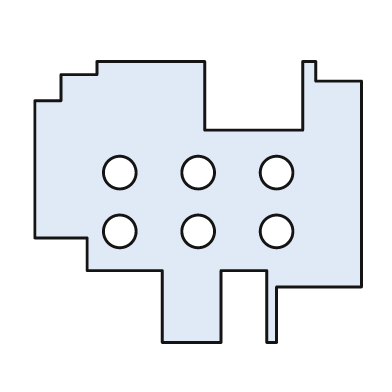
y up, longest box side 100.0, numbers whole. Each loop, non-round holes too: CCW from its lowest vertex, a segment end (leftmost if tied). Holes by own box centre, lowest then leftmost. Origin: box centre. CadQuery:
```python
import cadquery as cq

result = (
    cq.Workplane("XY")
    .moveTo(-11.0, -43.0)
    .lineTo(7.0, -43.0)
    .lineTo(7.0, -21.0)
    .lineTo(21.0, -21.0)
    .lineTo(21.0, -43.0)
    .lineTo(24.0, -43.0)
    .lineTo(24.0, -26.0)
    .lineTo(50.0, -26.0)
    .lineTo(50.0, 37.0)
    .lineTo(36.0, 37.0)
    .lineTo(36.0, 43.0)
    .lineTo(32.0, 43.0)
    .lineTo(32.0, 22.0)
    .lineTo(2.0, 22.0)
    .lineTo(2.0, 43.0)
    .lineTo(-31.0, 43.0)
    .lineTo(-31.0, 39.0)
    .lineTo(-42.0, 39.0)
    .lineTo(-42.0, 31.0)
    .lineTo(-50.0, 31.0)
    .lineTo(-50.0, -11.0)
    .lineTo(-34.0, -11.0)
    .lineTo(-34.0, -21.0)
    .lineTo(-11.0, -21.0)
    .close()
    .moveTo(-24.0, -9.0)
    .circle(5.0)
    .moveTo(0.0, -9.0)
    .circle(5.0)
    .moveTo(24.0, -9.0)
    .circle(5.0)
    .moveTo(-24.0, 9.0)
    .circle(5.0)
    .moveTo(0.0, 9.0)
    .circle(5.0)
    .moveTo(24.0, 9.0)
    .circle(5.0)
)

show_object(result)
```